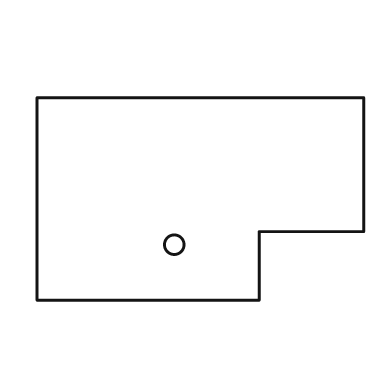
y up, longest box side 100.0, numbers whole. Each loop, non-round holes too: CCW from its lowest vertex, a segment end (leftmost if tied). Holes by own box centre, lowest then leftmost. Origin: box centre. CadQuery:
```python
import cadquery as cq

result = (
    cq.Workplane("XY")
    .moveTo(-50.0, -31.0)
    .lineTo(18.0, -31.0)
    .lineTo(18.0, -10.0)
    .lineTo(50.0, -10.0)
    .lineTo(50.0, 31.0)
    .lineTo(-50.0, 31.0)
    .close()
    .moveTo(-8.0, -14.0)
    .circle(3.0)
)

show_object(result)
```